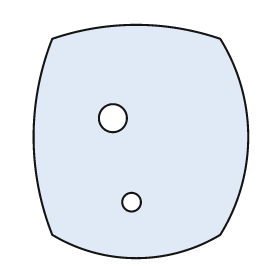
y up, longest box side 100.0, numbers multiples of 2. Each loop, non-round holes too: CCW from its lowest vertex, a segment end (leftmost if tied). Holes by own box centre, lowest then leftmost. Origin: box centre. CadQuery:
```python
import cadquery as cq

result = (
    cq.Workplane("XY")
    .moveTo(-38.0, -40.0)
    .threePointArc((-2.0, -50.0), (34.0, -40.0))
    .threePointArc((46.0, 2.0), (34.0, 44.0))
    .threePointArc((-2.0, 50.0), (-38.0, 44.0))
    .threePointArc((-46.0, 2.0), (-38.0, -40.0))
    .close()
    .moveTo(-4.0, -26.0)
    .circle(4.0)
    .moveTo(-12.0, 10.0)
    .circle(6.0)
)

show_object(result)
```